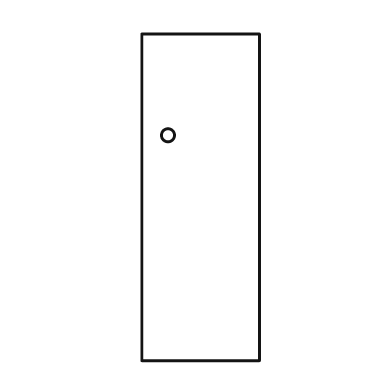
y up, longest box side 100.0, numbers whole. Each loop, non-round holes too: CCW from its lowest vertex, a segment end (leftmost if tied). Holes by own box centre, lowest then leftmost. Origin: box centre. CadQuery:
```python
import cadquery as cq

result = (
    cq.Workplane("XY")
    .moveTo(-18.0, -50.0)
    .lineTo(18.0, -50.0)
    .lineTo(18.0, 50.0)
    .lineTo(-18.0, 50.0)
    .close()
    .moveTo(-10.0, 19.0)
    .circle(2.0)
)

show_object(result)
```